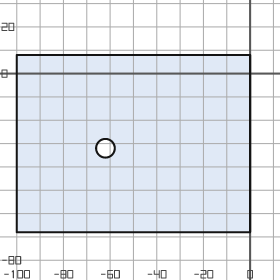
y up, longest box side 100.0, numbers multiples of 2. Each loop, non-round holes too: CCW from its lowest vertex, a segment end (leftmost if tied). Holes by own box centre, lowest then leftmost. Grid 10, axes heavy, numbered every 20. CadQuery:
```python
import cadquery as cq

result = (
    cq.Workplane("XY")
    .moveTo(-100.0, -68.0)
    .lineTo(0.0, -68.0)
    .lineTo(0.0, 8.0)
    .lineTo(-100.0, 8.0)
    .close()
    .moveTo(-62.0, -32.0)
    .circle(4.0)
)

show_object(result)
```